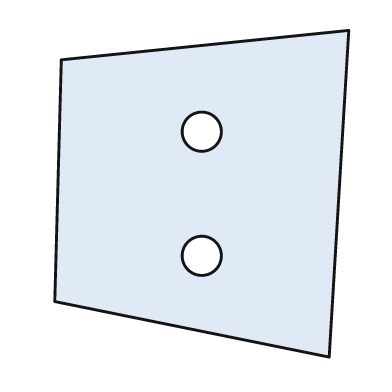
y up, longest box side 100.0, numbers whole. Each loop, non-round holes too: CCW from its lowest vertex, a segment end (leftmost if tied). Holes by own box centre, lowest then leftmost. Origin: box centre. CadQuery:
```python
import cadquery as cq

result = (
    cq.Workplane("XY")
    .moveTo(39.0, -50.0)
    .lineTo(45.0, 50.0)
    .lineTo(-43.0, 41.0)
    .lineTo(-45.0, -33.0)
    .close()
    .moveTo(0.0, -19.0)
    .circle(6.0)
    .moveTo(0.0, 19.0)
    .circle(6.0)
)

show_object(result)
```